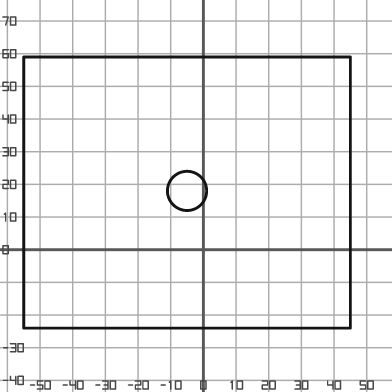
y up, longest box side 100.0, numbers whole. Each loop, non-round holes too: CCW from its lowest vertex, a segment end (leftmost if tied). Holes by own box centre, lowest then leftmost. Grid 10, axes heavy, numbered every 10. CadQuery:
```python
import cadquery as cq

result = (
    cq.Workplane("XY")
    .moveTo(-55.0, -24.0)
    .lineTo(45.0, -24.0)
    .lineTo(45.0, 59.0)
    .lineTo(-55.0, 59.0)
    .close()
    .moveTo(-5.0, 18.0)
    .circle(6.0)
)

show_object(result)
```